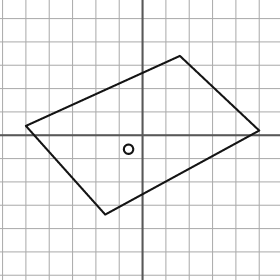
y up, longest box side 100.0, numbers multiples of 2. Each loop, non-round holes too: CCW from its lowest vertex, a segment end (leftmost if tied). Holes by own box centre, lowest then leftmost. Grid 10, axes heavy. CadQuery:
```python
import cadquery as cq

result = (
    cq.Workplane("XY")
    .moveTo(-16.0, -34.0)
    .lineTo(50.0, 2.0)
    .lineTo(16.0, 34.0)
    .lineTo(-50.0, 4.0)
    .close()
    .moveTo(-6.0, -6.0)
    .circle(2.0)
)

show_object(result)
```